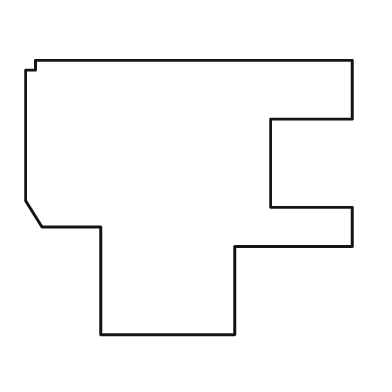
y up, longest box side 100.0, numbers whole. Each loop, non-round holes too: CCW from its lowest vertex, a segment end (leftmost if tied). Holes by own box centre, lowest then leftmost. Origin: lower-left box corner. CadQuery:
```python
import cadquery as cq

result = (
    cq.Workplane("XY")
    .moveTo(23.0, 0.0)
    .lineTo(64.0, 0.0)
    .lineTo(64.0, 27.0)
    .lineTo(100.0, 27.0)
    .lineTo(100.0, 39.0)
    .lineTo(75.0, 39.0)
    .lineTo(75.0, 66.0)
    .lineTo(100.0, 66.0)
    .lineTo(100.0, 84.0)
    .lineTo(3.0, 84.0)
    .lineTo(3.0, 81.0)
    .lineTo(0.0, 81.0)
    .lineTo(0.0, 41.0)
    .lineTo(5.0, 33.0)
    .lineTo(23.0, 33.0)
    .close()
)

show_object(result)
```